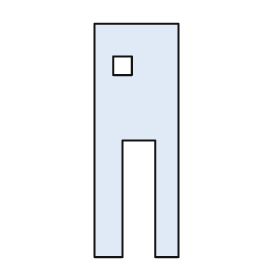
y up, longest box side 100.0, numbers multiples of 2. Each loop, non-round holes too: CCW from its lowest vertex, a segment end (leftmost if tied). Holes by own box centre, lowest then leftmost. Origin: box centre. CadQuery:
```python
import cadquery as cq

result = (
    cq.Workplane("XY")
    .moveTo(-18.0, -50.0)
    .lineTo(-6.0, -50.0)
    .lineTo(-6.0, 0.0)
    .lineTo(8.0, 0.0)
    .lineTo(8.0, -50.0)
    .lineTo(18.0, -50.0)
    .lineTo(18.0, 50.0)
    .lineTo(-18.0, 50.0)
    .close()
    .moveTo(-10.0, 28.0)
    .lineTo(-2.0, 28.0)
    .lineTo(-2.0, 36.0)
    .lineTo(-10.0, 36.0)
    .close()
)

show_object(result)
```